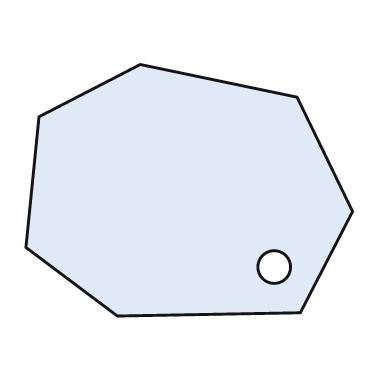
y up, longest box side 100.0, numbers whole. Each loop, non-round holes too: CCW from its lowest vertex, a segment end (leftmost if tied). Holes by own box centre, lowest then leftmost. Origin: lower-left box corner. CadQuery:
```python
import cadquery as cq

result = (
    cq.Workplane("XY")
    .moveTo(28.0, 0.0)
    .lineTo(84.0, 1.0)
    .lineTo(100.0, 32.0)
    .lineTo(83.0, 67.0)
    .lineTo(35.0, 77.0)
    .lineTo(4.0, 61.0)
    .lineTo(0.0, 21.0)
    .close()
    .moveTo(76.0, 15.0)
    .circle(5.0)
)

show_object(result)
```